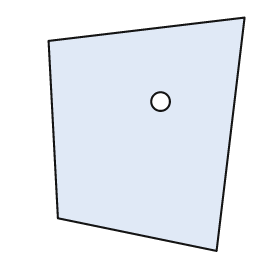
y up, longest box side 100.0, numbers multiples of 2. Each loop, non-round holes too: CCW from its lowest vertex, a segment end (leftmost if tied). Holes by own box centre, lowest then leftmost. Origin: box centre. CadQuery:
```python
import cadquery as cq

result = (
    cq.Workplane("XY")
    .moveTo(30.0, -50.0)
    .lineTo(42.0, 50.0)
    .lineTo(-42.0, 40.0)
    .lineTo(-38.0, -36.0)
    .close()
    .moveTo(6.0, 14.0)
    .circle(4.0)
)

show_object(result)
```